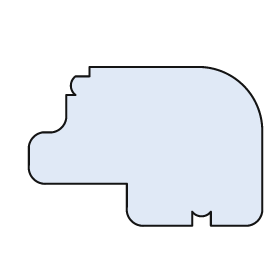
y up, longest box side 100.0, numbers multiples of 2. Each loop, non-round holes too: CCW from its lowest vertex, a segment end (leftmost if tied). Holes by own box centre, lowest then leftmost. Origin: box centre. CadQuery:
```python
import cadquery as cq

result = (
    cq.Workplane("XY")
    .moveTo(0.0, -34.0)
    .lineTo(20.0, -34.0)
    .lineTo(20.0, -28.0)
    .threePointArc((24.0, -30.0), (28.0, -28.0))
    .lineTo(28.0, -34.0)
    .lineTo(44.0, -34.0)
    .threePointArc((48.0, -32.0), (50.0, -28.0))
    .lineTo(50.0, 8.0)
    .threePointArc((42.0, 26.0), (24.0, 34.0))
    .lineTo(-24.0, 34.0)
    .lineTo(-24.0, 30.0)
    .lineTo(-30.0, 30.0)
    .threePointArc((-32.0, 26.0), (-30.0, 22.0))
    .lineTo(-34.0, 22.0)
    .lineTo(-34.0, 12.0)
    .threePointArc((-36.0, 8.0), (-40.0, 6.0))
    .lineTo(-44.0, 6.0)
    .threePointArc((-48.0, 4.0), (-50.0, 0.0))
    .lineTo(-50.0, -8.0)
    .threePointArc((-48.0, -14.0), (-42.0, -16.0))
    .lineTo(-8.0, -16.0)
    .lineTo(-8.0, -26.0)
    .threePointArc((-6.0, -32.0), (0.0, -34.0))
    .close()
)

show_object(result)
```